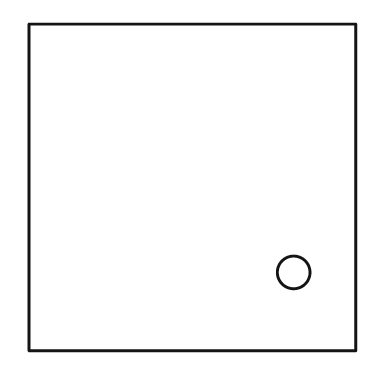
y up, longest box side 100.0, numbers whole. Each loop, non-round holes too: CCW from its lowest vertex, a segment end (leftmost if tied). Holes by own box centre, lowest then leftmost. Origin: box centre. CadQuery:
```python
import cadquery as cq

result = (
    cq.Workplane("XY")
    .moveTo(-50.0, -50.0)
    .lineTo(50.0, -50.0)
    .lineTo(50.0, 50.0)
    .lineTo(-50.0, 50.0)
    .close()
    .moveTo(31.0, -26.0)
    .circle(5.0)
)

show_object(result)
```